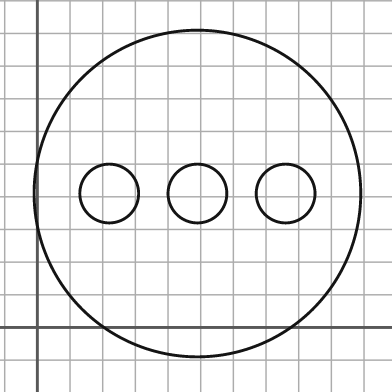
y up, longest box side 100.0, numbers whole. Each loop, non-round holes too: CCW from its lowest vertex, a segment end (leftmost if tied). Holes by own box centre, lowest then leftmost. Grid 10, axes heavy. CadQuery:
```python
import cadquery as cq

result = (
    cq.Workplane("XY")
    .moveTo(49.0, 41.0)
    .circle(50.0)
    .moveTo(22.0, 41.0)
    .circle(9.0)
    .moveTo(49.0, 41.0)
    .circle(9.0)
    .moveTo(76.0, 41.0)
    .circle(9.0)
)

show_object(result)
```